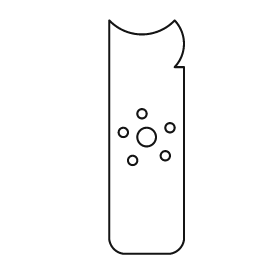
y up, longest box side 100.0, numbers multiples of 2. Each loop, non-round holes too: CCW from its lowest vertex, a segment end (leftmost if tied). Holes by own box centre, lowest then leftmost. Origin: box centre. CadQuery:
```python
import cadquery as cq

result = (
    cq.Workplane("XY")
    .moveTo(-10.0, -50.0)
    .lineTo(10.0, -50.0)
    .threePointArc((14.0, -48.0), (16.0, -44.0))
    .lineTo(16.0, 30.0)
    .lineTo(12.0, 30.0)
    .threePointArc((16.0, 40.0), (12.0, 50.0))
    .threePointArc((-2.0, 44.0), (-16.0, 50.0))
    .lineTo(-16.0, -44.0)
    .threePointArc((-14.0, -48.0), (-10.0, -50.0))
    .close()
    .moveTo(-6.0, -10.0)
    .circle(2.0)
    .moveTo(8.0, -8.0)
    .circle(2.0)
    .moveTo(0.0, 0.0)
    .circle(4.0)
    .moveTo(-10.0, 2.0)
    .circle(2.0)
    .moveTo(10.0, 4.0)
    .circle(2.0)
    .moveTo(-2.0, 10.0)
    .circle(2.0)
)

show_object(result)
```